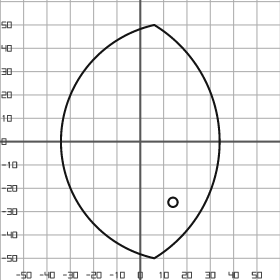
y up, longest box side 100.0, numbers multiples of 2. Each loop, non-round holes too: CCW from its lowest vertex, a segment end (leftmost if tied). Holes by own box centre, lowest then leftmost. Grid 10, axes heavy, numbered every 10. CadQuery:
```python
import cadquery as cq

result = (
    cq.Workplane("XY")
    .moveTo(6.0, -50.0)
    .threePointArc((34.0, 0.0), (6.0, 50.0))
    .threePointArc((-34.0, 0.0), (6.0, -50.0))
    .close()
    .moveTo(14.0, -26.0)
    .circle(2.0)
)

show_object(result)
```